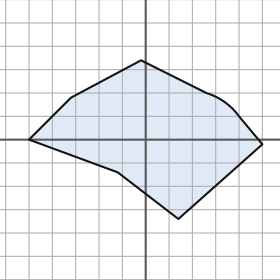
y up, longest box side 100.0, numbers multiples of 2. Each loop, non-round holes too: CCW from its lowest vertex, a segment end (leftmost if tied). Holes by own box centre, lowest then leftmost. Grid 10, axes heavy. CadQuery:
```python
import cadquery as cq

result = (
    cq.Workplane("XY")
    .moveTo(14.0, -34.0)
    .lineTo(50.0, -2.0)
    .lineTo(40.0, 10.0)
    .threePointArc((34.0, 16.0), (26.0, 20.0))
    .lineTo(-2.0, 34.0)
    .lineTo(-32.0, 18.0)
    .lineTo(-50.0, 0.0)
    .lineTo(-12.0, -14.0)
    .close()
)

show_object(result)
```